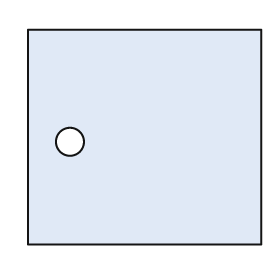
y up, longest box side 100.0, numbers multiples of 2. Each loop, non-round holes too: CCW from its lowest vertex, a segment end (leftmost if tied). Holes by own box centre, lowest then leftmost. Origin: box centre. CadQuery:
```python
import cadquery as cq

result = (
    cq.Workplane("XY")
    .moveTo(-50.0, -46.0)
    .lineTo(50.0, -46.0)
    .lineTo(50.0, 46.0)
    .lineTo(-50.0, 46.0)
    .close()
    .moveTo(-32.0, -2.0)
    .circle(6.0)
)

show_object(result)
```